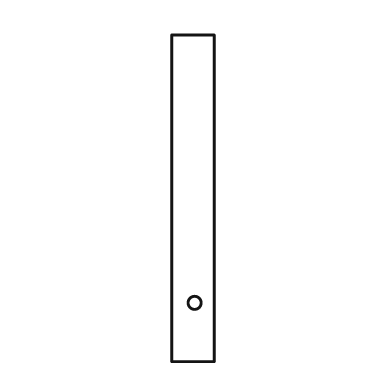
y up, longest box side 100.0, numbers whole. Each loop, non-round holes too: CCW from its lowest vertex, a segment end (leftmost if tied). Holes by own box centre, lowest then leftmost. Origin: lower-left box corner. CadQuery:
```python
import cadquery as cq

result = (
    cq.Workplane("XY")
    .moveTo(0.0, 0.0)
    .lineTo(13.0, 0.0)
    .lineTo(13.0, 100.0)
    .lineTo(0.0, 100.0)
    .close()
    .moveTo(7.0, 18.0)
    .circle(2.0)
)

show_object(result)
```